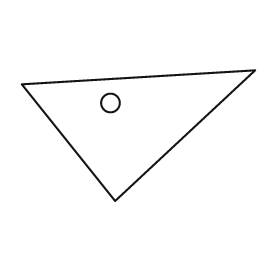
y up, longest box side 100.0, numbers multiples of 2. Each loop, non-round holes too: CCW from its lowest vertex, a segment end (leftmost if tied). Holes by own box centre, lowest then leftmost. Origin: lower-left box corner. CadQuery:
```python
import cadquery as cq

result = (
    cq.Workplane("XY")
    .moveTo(40.0, 0.0)
    .lineTo(100.0, 56.0)
    .lineTo(0.0, 50.0)
    .close()
    .moveTo(38.0, 42.0)
    .circle(4.0)
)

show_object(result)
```